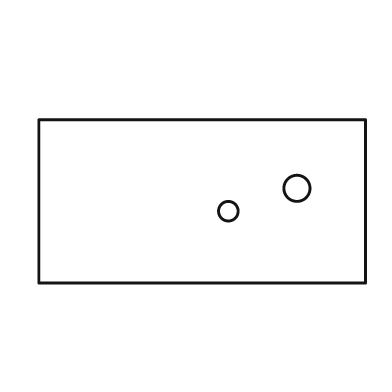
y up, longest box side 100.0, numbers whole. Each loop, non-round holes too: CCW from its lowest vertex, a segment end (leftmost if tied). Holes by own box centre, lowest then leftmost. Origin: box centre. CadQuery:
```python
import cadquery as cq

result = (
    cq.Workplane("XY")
    .moveTo(-50.0, -25.0)
    .lineTo(50.0, -25.0)
    .lineTo(50.0, 25.0)
    .lineTo(-50.0, 25.0)
    .close()
    .moveTo(8.0, -3.0)
    .circle(3.0)
    .moveTo(29.0, 4.0)
    .circle(4.0)
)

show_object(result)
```